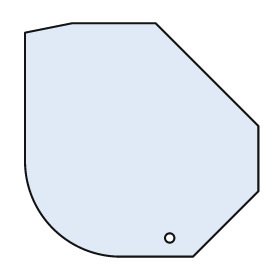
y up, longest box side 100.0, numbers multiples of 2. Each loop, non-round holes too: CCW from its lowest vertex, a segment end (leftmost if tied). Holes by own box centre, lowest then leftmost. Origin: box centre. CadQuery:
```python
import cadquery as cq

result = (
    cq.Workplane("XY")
    .moveTo(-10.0, -50.0)
    .lineTo(22.0, -50.0)
    .lineTo(50.0, -22.0)
    .lineTo(50.0, 6.0)
    .lineTo(6.0, 50.0)
    .lineTo(-30.0, 50.0)
    .lineTo(-50.0, 46.0)
    .lineTo(-50.0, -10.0)
    .threePointArc((-38.0, -38.0), (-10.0, -50.0))
    .close()
    .moveTo(12.0, -42.0)
    .circle(2.0)
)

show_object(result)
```